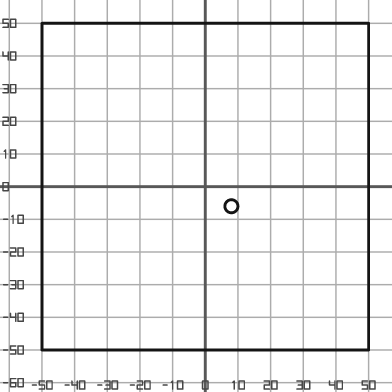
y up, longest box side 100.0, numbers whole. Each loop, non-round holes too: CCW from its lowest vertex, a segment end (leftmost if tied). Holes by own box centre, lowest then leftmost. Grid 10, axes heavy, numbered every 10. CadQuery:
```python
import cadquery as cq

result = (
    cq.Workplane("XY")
    .moveTo(-50.0, -50.0)
    .lineTo(50.0, -50.0)
    .lineTo(50.0, 50.0)
    .lineTo(-50.0, 50.0)
    .close()
    .moveTo(8.0, -6.0)
    .circle(2.0)
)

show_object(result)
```